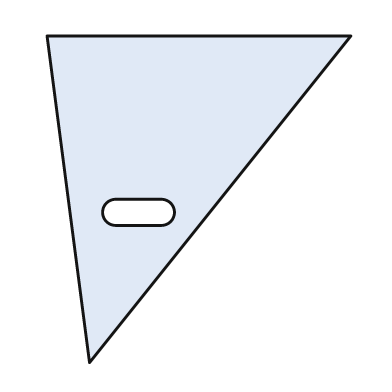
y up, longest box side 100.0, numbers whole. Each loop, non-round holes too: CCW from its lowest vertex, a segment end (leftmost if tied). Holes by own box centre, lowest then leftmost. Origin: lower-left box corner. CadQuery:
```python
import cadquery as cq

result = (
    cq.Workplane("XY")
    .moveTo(13.0, 0.0)
    .lineTo(93.0, 100.0)
    .lineTo(0.0, 100.0)
    .close()
    .moveTo(21.0, 42.0)
    .lineTo(35.0, 42.0)
    .threePointArc((39.0, 46.0), (35.0, 50.0))
    .lineTo(21.0, 50.0)
    .threePointArc((17.0, 46.0), (21.0, 42.0))
    .close()
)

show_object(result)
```